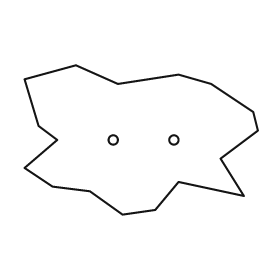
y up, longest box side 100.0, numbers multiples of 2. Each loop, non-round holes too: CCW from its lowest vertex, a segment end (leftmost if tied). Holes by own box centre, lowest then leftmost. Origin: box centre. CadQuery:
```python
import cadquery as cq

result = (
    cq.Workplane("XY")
    .moveTo(-8.0, -32.0)
    .lineTo(6.0, -30.0)
    .lineTo(16.0, -18.0)
    .lineTo(44.0, -24.0)
    .lineTo(34.0, -8.0)
    .lineTo(50.0, 4.0)
    .lineTo(48.0, 12.0)
    .lineTo(30.0, 24.0)
    .lineTo(16.0, 28.0)
    .lineTo(-10.0, 24.0)
    .lineTo(-28.0, 32.0)
    .lineTo(-50.0, 26.0)
    .lineTo(-44.0, 6.0)
    .lineTo(-36.0, 0.0)
    .lineTo(-50.0, -12.0)
    .lineTo(-38.0, -20.0)
    .lineTo(-22.0, -22.0)
    .close()
    .moveTo(-12.0, 0.0)
    .circle(2.0)
    .moveTo(14.0, 0.0)
    .circle(2.0)
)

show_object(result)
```